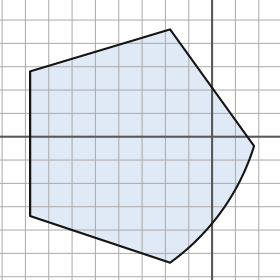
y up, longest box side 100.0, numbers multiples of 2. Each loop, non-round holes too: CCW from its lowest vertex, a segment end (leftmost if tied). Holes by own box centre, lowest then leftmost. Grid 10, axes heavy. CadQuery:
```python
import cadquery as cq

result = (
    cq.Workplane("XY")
    .moveTo(-18.0, -54.0)
    .threePointArc((4.0, -32.0), (18.0, -4.0))
    .lineTo(-18.0, 46.0)
    .lineTo(-78.0, 28.0)
    .lineTo(-78.0, -34.0)
    .close()
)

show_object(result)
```